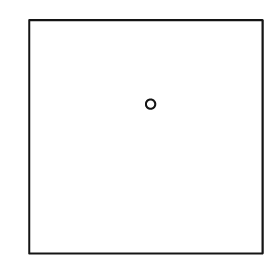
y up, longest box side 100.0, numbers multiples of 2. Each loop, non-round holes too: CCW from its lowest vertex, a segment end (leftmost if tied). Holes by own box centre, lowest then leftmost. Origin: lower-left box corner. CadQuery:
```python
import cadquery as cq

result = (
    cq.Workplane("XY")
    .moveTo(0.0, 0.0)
    .lineTo(100.0, 0.0)
    .lineTo(100.0, 100.0)
    .lineTo(0.0, 100.0)
    .close()
    .moveTo(52.0, 64.0)
    .circle(2.0)
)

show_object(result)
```